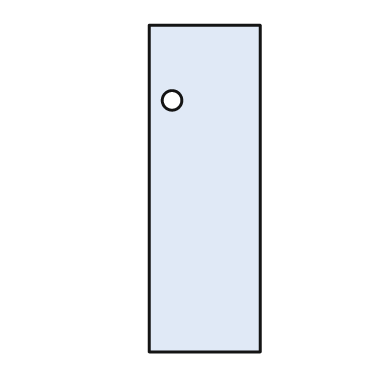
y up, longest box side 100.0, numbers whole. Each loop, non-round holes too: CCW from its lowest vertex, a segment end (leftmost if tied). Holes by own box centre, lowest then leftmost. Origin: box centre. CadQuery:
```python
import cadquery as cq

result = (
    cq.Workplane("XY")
    .moveTo(-17.0, -50.0)
    .lineTo(17.0, -50.0)
    .lineTo(17.0, 50.0)
    .lineTo(-17.0, 50.0)
    .close()
    .moveTo(-10.0, 27.0)
    .circle(3.0)
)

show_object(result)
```